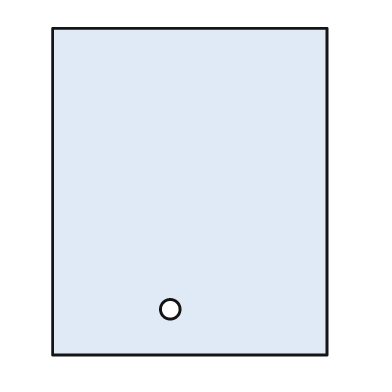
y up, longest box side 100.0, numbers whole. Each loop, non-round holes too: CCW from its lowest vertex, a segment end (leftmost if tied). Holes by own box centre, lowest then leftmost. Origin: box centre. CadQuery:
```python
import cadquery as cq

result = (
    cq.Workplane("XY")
    .moveTo(-42.0, -50.0)
    .lineTo(42.0, -50.0)
    .lineTo(42.0, 50.0)
    .lineTo(-42.0, 50.0)
    .close()
    .moveTo(-6.0, -36.0)
    .circle(3.0)
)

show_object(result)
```